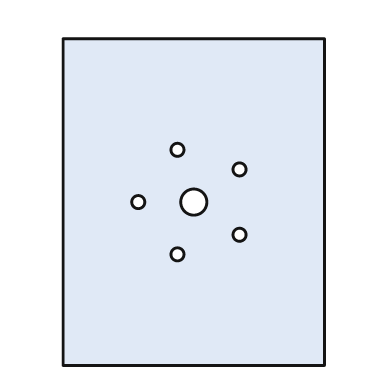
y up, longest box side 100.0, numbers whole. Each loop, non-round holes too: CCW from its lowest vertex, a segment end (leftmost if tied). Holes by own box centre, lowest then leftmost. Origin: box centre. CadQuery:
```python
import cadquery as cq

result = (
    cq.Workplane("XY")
    .moveTo(-40.0, -50.0)
    .lineTo(40.0, -50.0)
    .lineTo(40.0, 50.0)
    .lineTo(-40.0, 50.0)
    .close()
    .moveTo(-5.0, -16.0)
    .circle(2.0)
    .moveTo(14.0, -10.0)
    .circle(2.0)
    .moveTo(-17.0, 0.0)
    .circle(2.0)
    .moveTo(0.0, 0.0)
    .circle(4.0)
    .moveTo(14.0, 10.0)
    .circle(2.0)
    .moveTo(-5.0, 16.0)
    .circle(2.0)
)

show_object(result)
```